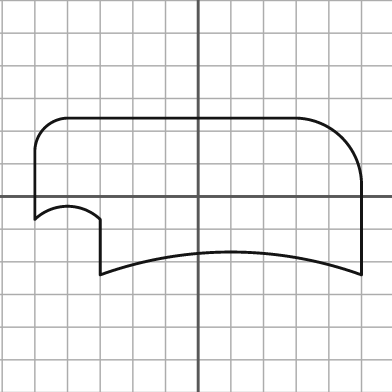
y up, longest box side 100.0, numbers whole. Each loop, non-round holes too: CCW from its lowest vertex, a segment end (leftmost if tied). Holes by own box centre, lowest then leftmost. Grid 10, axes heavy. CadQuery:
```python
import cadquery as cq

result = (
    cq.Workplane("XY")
    .moveTo(-30.0, -24.0)
    .threePointArc((10.0, -17.0), (50.0, -24.0))
    .lineTo(50.0, 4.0)
    .threePointArc((44.0, 18.0), (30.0, 24.0))
    .lineTo(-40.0, 24.0)
    .threePointArc((-47.0, 21.0), (-50.0, 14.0))
    .lineTo(-50.0, -7.0)
    .threePointArc((-40.0, -3.0), (-30.0, -7.0))
    .close()
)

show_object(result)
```